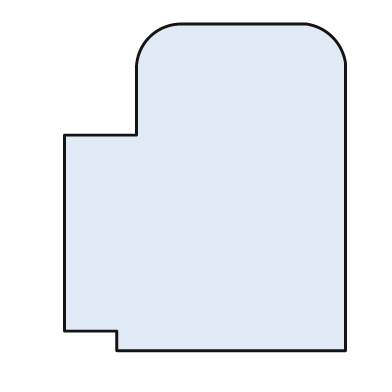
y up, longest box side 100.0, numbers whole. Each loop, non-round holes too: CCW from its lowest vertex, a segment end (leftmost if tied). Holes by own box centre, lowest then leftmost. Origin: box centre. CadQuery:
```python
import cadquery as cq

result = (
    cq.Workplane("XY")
    .moveTo(-27.0, -50.0)
    .lineTo(43.0, -50.0)
    .lineTo(43.0, 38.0)
    .threePointArc((39.0, 46.0), (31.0, 50.0))
    .lineTo(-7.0, 50.0)
    .threePointArc((-17.0, 46.0), (-21.0, 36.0))
    .lineTo(-21.0, 16.0)
    .lineTo(-43.0, 16.0)
    .lineTo(-43.0, -44.0)
    .lineTo(-27.0, -44.0)
    .close()
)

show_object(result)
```